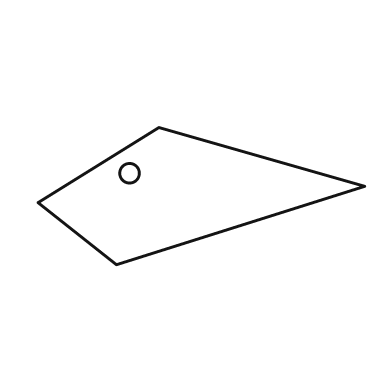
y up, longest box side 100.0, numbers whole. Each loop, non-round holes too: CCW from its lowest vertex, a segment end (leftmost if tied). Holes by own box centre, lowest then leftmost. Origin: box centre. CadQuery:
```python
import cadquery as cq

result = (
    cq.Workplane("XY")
    .moveTo(-26.0, -21.0)
    .lineTo(50.0, 3.0)
    .lineTo(-13.0, 21.0)
    .lineTo(-50.0, -2.0)
    .close()
    .moveTo(-22.0, 7.0)
    .circle(3.0)
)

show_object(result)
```